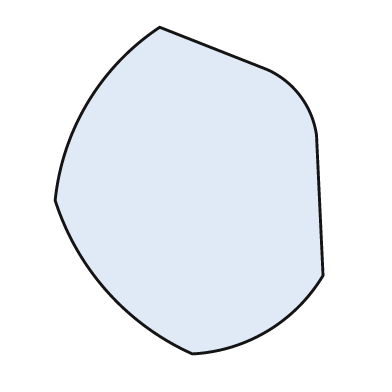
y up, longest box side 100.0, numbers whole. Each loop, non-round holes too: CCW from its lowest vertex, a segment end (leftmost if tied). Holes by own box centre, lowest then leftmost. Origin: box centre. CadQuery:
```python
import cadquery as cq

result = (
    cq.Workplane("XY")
    .moveTo(1.0, -50.0)
    .threePointArc((24.0, -43.0), (41.0, -26.0))
    .lineTo(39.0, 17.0)
    .threePointArc((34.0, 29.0), (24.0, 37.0))
    .lineTo(-9.0, 50.0)
    .threePointArc((-31.0, 27.0), (-41.0, -3.0))
    .threePointArc((-25.0, -31.0), (1.0, -50.0))
    .close()
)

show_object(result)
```